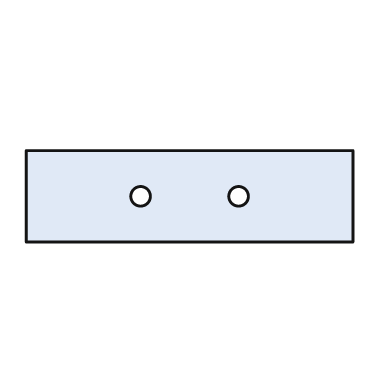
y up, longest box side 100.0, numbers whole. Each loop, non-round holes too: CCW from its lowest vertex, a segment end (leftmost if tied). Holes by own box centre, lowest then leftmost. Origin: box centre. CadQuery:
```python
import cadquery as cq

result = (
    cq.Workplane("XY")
    .moveTo(-50.0, -14.0)
    .lineTo(50.0, -14.0)
    .lineTo(50.0, 14.0)
    .lineTo(-50.0, 14.0)
    .close()
    .moveTo(-15.0, 0.0)
    .circle(3.0)
    .moveTo(15.0, 0.0)
    .circle(3.0)
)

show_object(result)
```